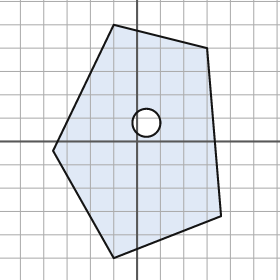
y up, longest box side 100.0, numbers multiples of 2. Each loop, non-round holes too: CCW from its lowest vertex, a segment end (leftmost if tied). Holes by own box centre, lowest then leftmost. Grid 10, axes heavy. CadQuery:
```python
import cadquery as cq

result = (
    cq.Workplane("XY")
    .moveTo(-10.0, -50.0)
    .lineTo(36.0, -32.0)
    .lineTo(30.0, 40.0)
    .lineTo(-10.0, 50.0)
    .lineTo(-36.0, -4.0)
    .close()
    .moveTo(4.0, 8.0)
    .circle(6.0)
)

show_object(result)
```